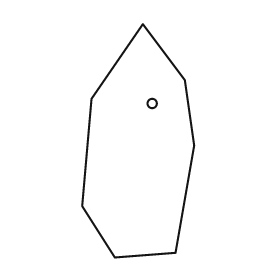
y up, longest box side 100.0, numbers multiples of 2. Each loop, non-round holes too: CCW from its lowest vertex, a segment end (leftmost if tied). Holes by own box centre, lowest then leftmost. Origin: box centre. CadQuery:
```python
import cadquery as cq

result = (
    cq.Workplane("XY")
    .moveTo(-10.0, -50.0)
    .lineTo(16.0, -48.0)
    .lineTo(24.0, -2.0)
    .lineTo(20.0, 26.0)
    .lineTo(2.0, 50.0)
    .lineTo(-20.0, 18.0)
    .lineTo(-24.0, -28.0)
    .close()
    .moveTo(6.0, 16.0)
    .circle(2.0)
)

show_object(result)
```